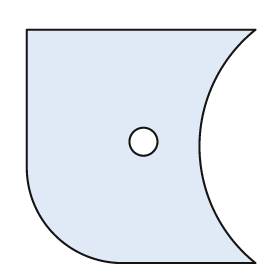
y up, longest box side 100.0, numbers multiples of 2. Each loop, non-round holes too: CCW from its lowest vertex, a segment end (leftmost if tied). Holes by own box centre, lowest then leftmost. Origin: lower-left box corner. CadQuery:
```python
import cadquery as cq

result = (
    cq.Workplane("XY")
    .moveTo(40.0, 0.0)
    .lineTo(98.0, 0.0)
    .threePointArc((74.0, 50.0), (98.0, 100.0))
    .lineTo(0.0, 100.0)
    .lineTo(0.0, 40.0)
    .threePointArc((12.0, 12.0), (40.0, 0.0))
    .close()
    .moveTo(50.0, 52.0)
    .circle(6.0)
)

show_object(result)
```